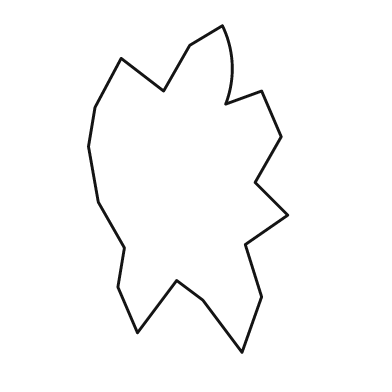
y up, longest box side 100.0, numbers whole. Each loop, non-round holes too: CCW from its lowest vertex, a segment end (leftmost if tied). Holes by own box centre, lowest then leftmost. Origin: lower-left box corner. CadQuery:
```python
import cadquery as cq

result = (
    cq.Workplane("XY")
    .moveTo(47.0, 0.0)
    .lineTo(53.0, 17.0)
    .lineTo(48.0, 33.0)
    .lineTo(61.0, 42.0)
    .lineTo(51.0, 52.0)
    .lineTo(59.0, 66.0)
    .lineTo(53.0, 80.0)
    .lineTo(42.0, 76.0)
    .threePointArc((44.0, 88.0), (41.0, 100.0))
    .lineTo(31.0, 94.0)
    .lineTo(23.0, 80.0)
    .lineTo(10.0, 90.0)
    .lineTo(2.0, 75.0)
    .lineTo(0.0, 63.0)
    .lineTo(3.0, 46.0)
    .lineTo(11.0, 32.0)
    .lineTo(9.0, 20.0)
    .lineTo(15.0, 6.0)
    .lineTo(27.0, 22.0)
    .lineTo(35.0, 16.0)
    .close()
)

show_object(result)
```